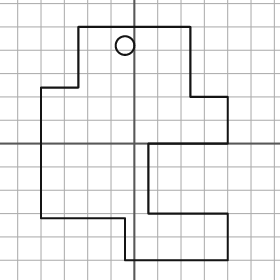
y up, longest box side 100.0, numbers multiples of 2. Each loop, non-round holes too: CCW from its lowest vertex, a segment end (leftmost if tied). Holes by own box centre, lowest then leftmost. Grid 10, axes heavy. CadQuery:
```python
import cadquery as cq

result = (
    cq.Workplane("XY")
    .moveTo(-4.0, -50.0)
    .lineTo(40.0, -50.0)
    .lineTo(40.0, -30.0)
    .lineTo(6.0, -30.0)
    .lineTo(6.0, 0.0)
    .lineTo(40.0, 0.0)
    .lineTo(40.0, 20.0)
    .lineTo(24.0, 20.0)
    .lineTo(24.0, 50.0)
    .lineTo(-24.0, 50.0)
    .lineTo(-24.0, 24.0)
    .lineTo(-40.0, 24.0)
    .lineTo(-40.0, -32.0)
    .lineTo(-4.0, -32.0)
    .close()
    .moveTo(-4.0, 42.0)
    .circle(4.0)
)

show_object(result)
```